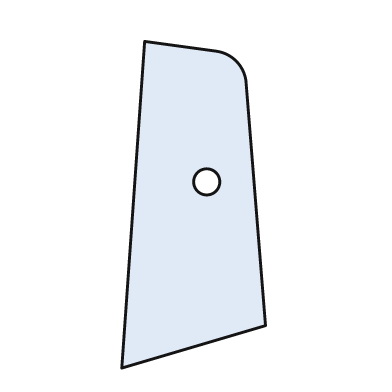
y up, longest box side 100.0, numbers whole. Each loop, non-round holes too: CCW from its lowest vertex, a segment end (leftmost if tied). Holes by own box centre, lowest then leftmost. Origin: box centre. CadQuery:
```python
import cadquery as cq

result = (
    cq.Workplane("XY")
    .moveTo(-22.0, -50.0)
    .lineTo(22.0, -37.0)
    .lineTo(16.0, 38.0)
    .threePointArc((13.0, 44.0), (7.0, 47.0))
    .lineTo(-15.0, 50.0)
    .close()
    .moveTo(4.0, 7.0)
    .circle(4.0)
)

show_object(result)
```